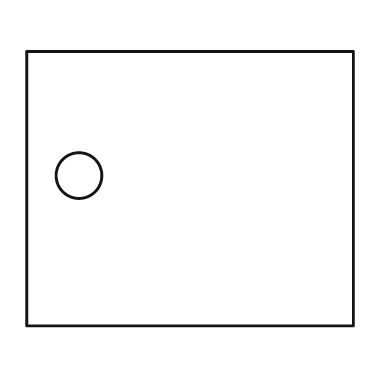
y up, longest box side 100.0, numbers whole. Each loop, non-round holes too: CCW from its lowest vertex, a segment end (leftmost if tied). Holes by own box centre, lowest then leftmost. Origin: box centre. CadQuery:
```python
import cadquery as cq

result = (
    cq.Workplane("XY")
    .moveTo(-50.0, -42.0)
    .lineTo(50.0, -42.0)
    .lineTo(50.0, 42.0)
    .lineTo(-50.0, 42.0)
    .close()
    .moveTo(-34.0, 4.0)
    .circle(7.0)
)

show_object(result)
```